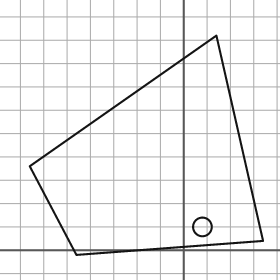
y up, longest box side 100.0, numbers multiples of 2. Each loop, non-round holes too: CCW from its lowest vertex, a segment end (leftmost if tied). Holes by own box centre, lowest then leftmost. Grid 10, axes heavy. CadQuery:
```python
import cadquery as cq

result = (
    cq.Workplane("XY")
    .moveTo(-46.0, -2.0)
    .lineTo(34.0, 4.0)
    .lineTo(14.0, 92.0)
    .lineTo(-66.0, 36.0)
    .close()
    .moveTo(8.0, 10.0)
    .circle(4.0)
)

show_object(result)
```